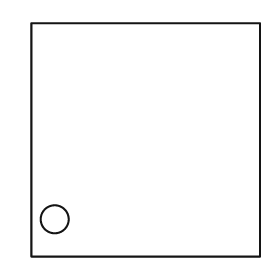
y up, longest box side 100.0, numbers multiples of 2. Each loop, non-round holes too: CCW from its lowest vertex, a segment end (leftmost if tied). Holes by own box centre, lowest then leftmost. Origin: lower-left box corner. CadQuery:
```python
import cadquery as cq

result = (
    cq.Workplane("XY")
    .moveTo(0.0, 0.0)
    .lineTo(98.0, 0.0)
    .lineTo(98.0, 100.0)
    .lineTo(0.0, 100.0)
    .close()
    .moveTo(10.0, 16.0)
    .circle(6.0)
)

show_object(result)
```